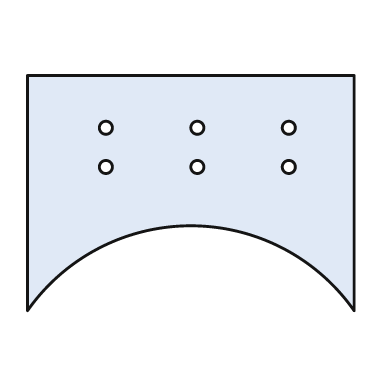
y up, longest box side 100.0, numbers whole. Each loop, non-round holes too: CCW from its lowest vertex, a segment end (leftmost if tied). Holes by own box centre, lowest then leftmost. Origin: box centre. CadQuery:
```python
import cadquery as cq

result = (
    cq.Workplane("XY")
    .moveTo(-50.0, -36.0)
    .threePointArc((0.0, -10.0), (50.0, -36.0))
    .lineTo(50.0, 36.0)
    .lineTo(-50.0, 36.0)
    .close()
    .moveTo(-26.0, 8.0)
    .circle(2.0)
    .moveTo(2.0, 8.0)
    .circle(2.0)
    .moveTo(30.0, 8.0)
    .circle(2.0)
    .moveTo(-26.0, 20.0)
    .circle(2.0)
    .moveTo(2.0, 20.0)
    .circle(2.0)
    .moveTo(30.0, 20.0)
    .circle(2.0)
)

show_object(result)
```